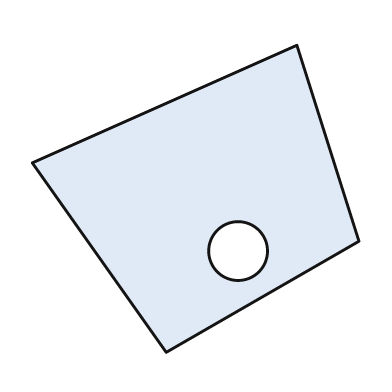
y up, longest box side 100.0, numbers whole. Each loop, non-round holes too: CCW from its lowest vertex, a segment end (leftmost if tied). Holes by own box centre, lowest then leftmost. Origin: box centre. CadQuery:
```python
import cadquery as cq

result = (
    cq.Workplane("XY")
    .moveTo(-9.0, -47.0)
    .lineTo(50.0, -13.0)
    .lineTo(31.0, 47.0)
    .lineTo(-50.0, 11.0)
    .close()
    .moveTo(13.0, -16.0)
    .circle(9.0)
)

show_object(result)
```